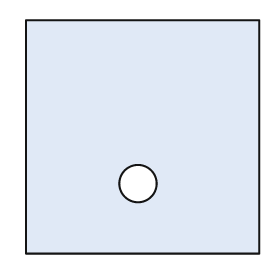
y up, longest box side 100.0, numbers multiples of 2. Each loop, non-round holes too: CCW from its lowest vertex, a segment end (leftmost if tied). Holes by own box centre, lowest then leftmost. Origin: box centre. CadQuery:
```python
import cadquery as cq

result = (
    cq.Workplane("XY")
    .moveTo(-50.0, -50.0)
    .lineTo(50.0, -50.0)
    .lineTo(50.0, 50.0)
    .lineTo(-50.0, 50.0)
    .close()
    .moveTo(-2.0, -20.0)
    .circle(8.0)
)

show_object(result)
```